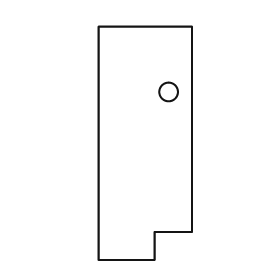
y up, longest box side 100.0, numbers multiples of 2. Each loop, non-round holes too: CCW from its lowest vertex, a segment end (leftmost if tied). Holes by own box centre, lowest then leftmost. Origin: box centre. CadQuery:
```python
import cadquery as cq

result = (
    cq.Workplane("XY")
    .moveTo(-20.0, -50.0)
    .lineTo(4.0, -50.0)
    .lineTo(4.0, -38.0)
    .lineTo(20.0, -38.0)
    .lineTo(20.0, 50.0)
    .lineTo(-20.0, 50.0)
    .close()
    .moveTo(10.0, 22.0)
    .circle(4.0)
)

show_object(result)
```